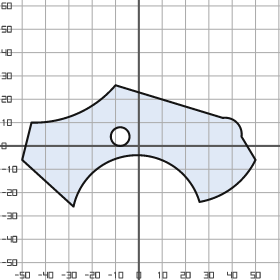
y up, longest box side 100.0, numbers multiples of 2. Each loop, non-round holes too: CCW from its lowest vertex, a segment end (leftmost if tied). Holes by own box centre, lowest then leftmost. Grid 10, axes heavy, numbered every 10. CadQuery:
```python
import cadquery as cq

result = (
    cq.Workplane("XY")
    .moveTo(-28.0, -26.0)
    .threePointArc((-2.0, -4.0), (26.0, -24.0))
    .threePointArc((40.0, -18.0), (50.0, -6.0))
    .lineTo(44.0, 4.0)
    .threePointArc((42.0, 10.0), (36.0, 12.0))
    .lineTo(-10.0, 26.0)
    .threePointArc((-26.0, 14.0), (-46.0, 10.0))
    .lineTo(-50.0, -6.0)
    .close()
    .moveTo(-8.0, 4.0)
    .circle(4.0)
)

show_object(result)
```